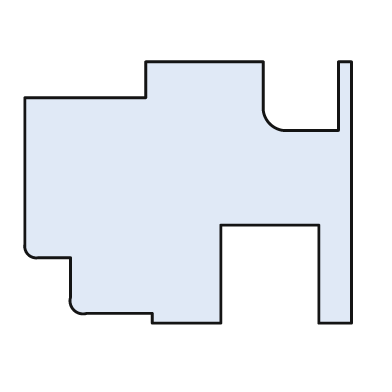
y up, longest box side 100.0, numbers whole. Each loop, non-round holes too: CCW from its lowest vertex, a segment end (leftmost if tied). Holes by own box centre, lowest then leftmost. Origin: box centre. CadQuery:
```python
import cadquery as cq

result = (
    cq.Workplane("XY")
    .moveTo(-11.0, -40.0)
    .lineTo(10.0, -40.0)
    .lineTo(10.0, -10.0)
    .lineTo(40.0, -10.0)
    .lineTo(40.0, -40.0)
    .lineTo(50.0, -40.0)
    .lineTo(50.0, 40.0)
    .lineTo(46.0, 40.0)
    .lineTo(46.0, 19.0)
    .lineTo(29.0, 19.0)
    .threePointArc((25.0, 21.0), (23.0, 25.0))
    .lineTo(23.0, 40.0)
    .lineTo(-13.0, 40.0)
    .lineTo(-13.0, 29.0)
    .lineTo(-50.0, 29.0)
    .lineTo(-50.0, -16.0)
    .threePointArc((-49.0, -19.0), (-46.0, -20.0))
    .lineTo(-36.0, -20.0)
    .lineTo(-36.0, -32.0)
    .threePointArc((-35.0, -36.0), (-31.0, -37.0))
    .lineTo(-11.0, -37.0)
    .close()
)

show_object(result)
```